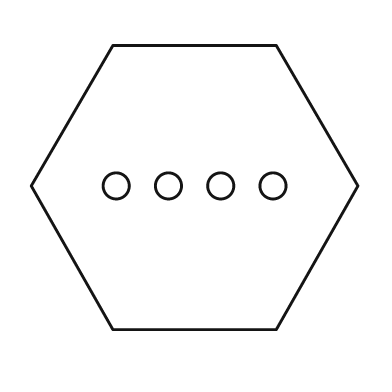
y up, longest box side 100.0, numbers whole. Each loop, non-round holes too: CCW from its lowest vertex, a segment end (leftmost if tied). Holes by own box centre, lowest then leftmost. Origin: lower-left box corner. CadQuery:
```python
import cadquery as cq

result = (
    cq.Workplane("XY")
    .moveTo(25.0, 0.0)
    .lineTo(75.0, 0.0)
    .lineTo(100.0, 44.0)
    .lineTo(75.0, 87.0)
    .lineTo(25.0, 87.0)
    .lineTo(0.0, 44.0)
    .close()
    .moveTo(26.0, 44.0)
    .circle(4.0)
    .moveTo(42.0, 44.0)
    .circle(4.0)
    .moveTo(58.0, 44.0)
    .circle(4.0)
    .moveTo(74.0, 44.0)
    .circle(4.0)
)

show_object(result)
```